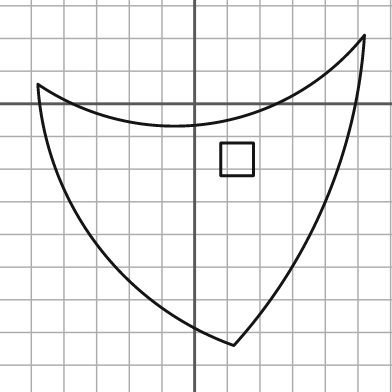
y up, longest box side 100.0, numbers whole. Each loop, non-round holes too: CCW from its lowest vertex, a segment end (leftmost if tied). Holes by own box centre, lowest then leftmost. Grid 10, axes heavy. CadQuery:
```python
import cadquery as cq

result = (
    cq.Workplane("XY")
    .moveTo(12.0, -74.0)
    .threePointArc((40.0, -30.0), (52.0, 21.0))
    .threePointArc((5.0, -6.0), (-48.0, 6.0))
    .threePointArc((-30.0, -43.0), (12.0, -74.0))
    .close()
    .moveTo(8.0, -22.0)
    .lineTo(18.0, -22.0)
    .lineTo(18.0, -12.0)
    .lineTo(8.0, -12.0)
    .close()
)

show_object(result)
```